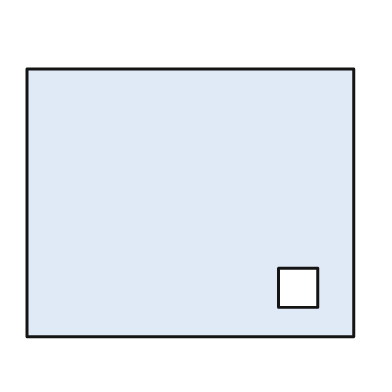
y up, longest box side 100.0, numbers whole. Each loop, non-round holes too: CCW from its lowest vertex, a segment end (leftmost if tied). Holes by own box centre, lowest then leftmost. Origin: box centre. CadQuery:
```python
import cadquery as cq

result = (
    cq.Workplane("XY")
    .moveTo(-50.0, -41.0)
    .lineTo(50.0, -41.0)
    .lineTo(50.0, 41.0)
    .lineTo(-50.0, 41.0)
    .close()
    .moveTo(27.0, -32.0)
    .lineTo(39.0, -32.0)
    .lineTo(39.0, -20.0)
    .lineTo(27.0, -20.0)
    .close()
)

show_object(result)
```